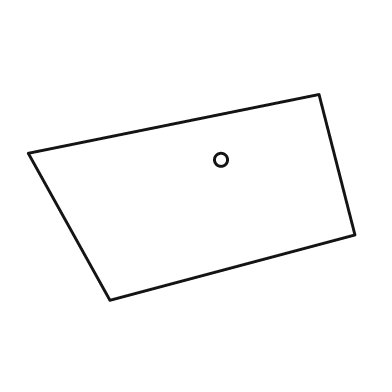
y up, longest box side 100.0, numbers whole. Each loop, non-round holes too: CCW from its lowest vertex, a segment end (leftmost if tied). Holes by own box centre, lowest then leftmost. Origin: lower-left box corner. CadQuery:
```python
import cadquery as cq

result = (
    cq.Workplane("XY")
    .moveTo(25.0, 0.0)
    .lineTo(100.0, 20.0)
    .lineTo(89.0, 63.0)
    .lineTo(0.0, 45.0)
    .close()
    .moveTo(59.0, 43.0)
    .circle(2.0)
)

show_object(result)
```